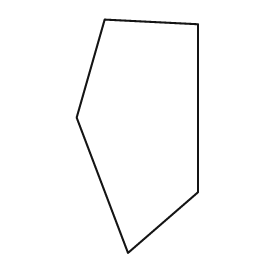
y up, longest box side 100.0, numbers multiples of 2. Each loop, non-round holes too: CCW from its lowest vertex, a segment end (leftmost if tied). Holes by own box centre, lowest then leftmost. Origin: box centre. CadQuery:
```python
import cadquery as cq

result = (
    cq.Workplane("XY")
    .moveTo(-4.0, -50.0)
    .lineTo(26.0, -24.0)
    .lineTo(26.0, 48.0)
    .lineTo(-14.0, 50.0)
    .lineTo(-26.0, 8.0)
    .close()
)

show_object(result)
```